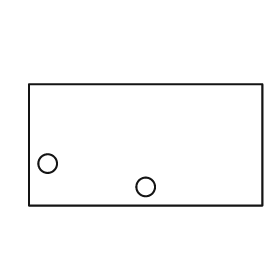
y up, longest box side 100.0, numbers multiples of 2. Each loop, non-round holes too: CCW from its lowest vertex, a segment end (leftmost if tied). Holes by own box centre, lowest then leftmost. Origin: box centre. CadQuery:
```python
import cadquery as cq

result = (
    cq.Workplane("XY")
    .moveTo(-50.0, -26.0)
    .lineTo(50.0, -26.0)
    .lineTo(50.0, 26.0)
    .lineTo(-50.0, 26.0)
    .close()
    .moveTo(0.0, -18.0)
    .circle(4.0)
    .moveTo(-42.0, -8.0)
    .circle(4.0)
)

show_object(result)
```